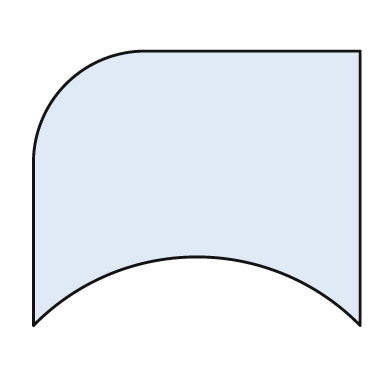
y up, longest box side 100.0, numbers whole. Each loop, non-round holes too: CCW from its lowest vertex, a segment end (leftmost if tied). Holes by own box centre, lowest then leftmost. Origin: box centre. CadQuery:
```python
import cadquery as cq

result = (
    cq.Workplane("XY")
    .moveTo(-50.0, -42.0)
    .threePointArc((0.0, -21.0), (50.0, -42.0))
    .lineTo(50.0, 42.0)
    .lineTo(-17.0, 42.0)
    .threePointArc((-40.0, 32.0), (-50.0, 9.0))
    .close()
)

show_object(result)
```